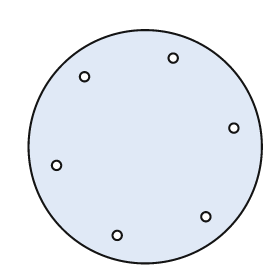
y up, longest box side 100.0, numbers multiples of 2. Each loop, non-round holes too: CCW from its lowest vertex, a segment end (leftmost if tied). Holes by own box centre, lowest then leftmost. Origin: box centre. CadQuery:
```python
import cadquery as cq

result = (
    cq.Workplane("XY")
    .moveTo(0.0, 0.0)
    .circle(50.0)
    .moveTo(-12.0, -38.0)
    .circle(2.0)
    .moveTo(26.0, -30.0)
    .circle(2.0)
    .moveTo(-38.0, -8.0)
    .circle(2.0)
    .moveTo(38.0, 8.0)
    .circle(2.0)
    .moveTo(-26.0, 30.0)
    .circle(2.0)
    .moveTo(12.0, 38.0)
    .circle(2.0)
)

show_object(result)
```